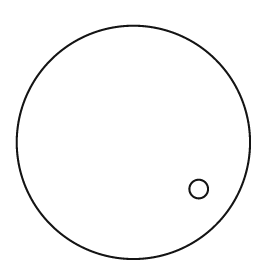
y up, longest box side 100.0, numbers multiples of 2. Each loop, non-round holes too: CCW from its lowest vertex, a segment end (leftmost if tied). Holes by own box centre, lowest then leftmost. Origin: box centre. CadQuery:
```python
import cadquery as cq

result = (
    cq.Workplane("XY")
    .moveTo(0.0, 0.0)
    .circle(50.0)
    .moveTo(28.0, -20.0)
    .circle(4.0)
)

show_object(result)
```